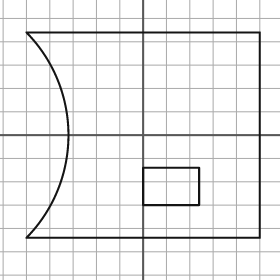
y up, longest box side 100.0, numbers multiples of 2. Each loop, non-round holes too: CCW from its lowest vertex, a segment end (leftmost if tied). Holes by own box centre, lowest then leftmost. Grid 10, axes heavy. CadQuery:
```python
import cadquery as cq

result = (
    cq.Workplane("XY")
    .moveTo(-50.0, -44.0)
    .lineTo(50.0, -44.0)
    .lineTo(50.0, 44.0)
    .lineTo(-50.0, 44.0)
    .threePointArc((-32.0, 0.0), (-50.0, -44.0))
    .close()
    .moveTo(0.0, -30.0)
    .lineTo(24.0, -30.0)
    .lineTo(24.0, -14.0)
    .lineTo(0.0, -14.0)
    .close()
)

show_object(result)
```